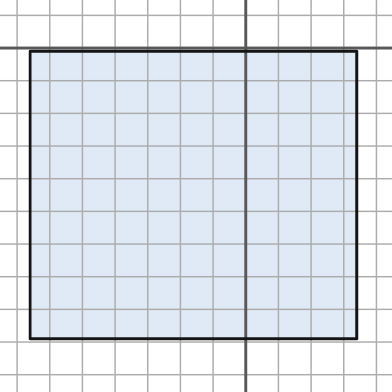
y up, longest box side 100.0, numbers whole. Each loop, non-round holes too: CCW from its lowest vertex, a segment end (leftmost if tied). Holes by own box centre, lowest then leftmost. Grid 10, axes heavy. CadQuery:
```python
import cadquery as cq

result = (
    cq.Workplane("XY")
    .moveTo(-66.0, -89.0)
    .lineTo(34.0, -89.0)
    .lineTo(34.0, -1.0)
    .lineTo(-66.0, -1.0)
    .close()
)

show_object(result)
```